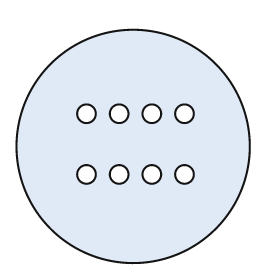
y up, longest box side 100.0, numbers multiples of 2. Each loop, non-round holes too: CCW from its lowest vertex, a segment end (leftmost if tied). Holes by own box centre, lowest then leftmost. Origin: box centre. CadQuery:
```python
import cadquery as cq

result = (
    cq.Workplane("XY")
    .moveTo(0.0, 0.0)
    .circle(50.0)
    .moveTo(-20.0, -12.0)
    .circle(4.0)
    .moveTo(-6.0, -12.0)
    .circle(4.0)
    .moveTo(8.0, -12.0)
    .circle(4.0)
    .moveTo(22.0, -12.0)
    .circle(4.0)
    .moveTo(-20.0, 14.0)
    .circle(4.0)
    .moveTo(-6.0, 14.0)
    .circle(4.0)
    .moveTo(8.0, 14.0)
    .circle(4.0)
    .moveTo(22.0, 14.0)
    .circle(4.0)
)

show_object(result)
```